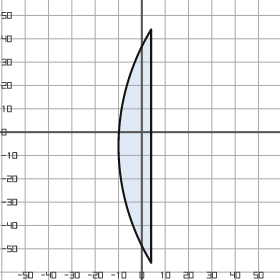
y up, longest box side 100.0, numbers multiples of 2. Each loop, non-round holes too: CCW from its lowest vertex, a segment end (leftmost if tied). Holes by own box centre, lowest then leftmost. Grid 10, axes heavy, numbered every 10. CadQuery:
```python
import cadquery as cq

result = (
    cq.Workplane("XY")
    .moveTo(4.0, -56.0)
    .lineTo(4.0, 44.0)
    .threePointArc((-10.0, -6.0), (4.0, -56.0))
    .close()
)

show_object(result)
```